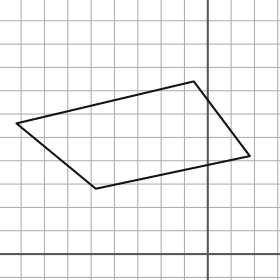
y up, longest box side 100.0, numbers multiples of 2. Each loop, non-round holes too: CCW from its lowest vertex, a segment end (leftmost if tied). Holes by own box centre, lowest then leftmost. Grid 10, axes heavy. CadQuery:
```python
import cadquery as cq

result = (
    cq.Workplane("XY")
    .moveTo(-48.0, 28.0)
    .lineTo(18.0, 42.0)
    .lineTo(-6.0, 74.0)
    .lineTo(-82.0, 56.0)
    .close()
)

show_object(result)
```